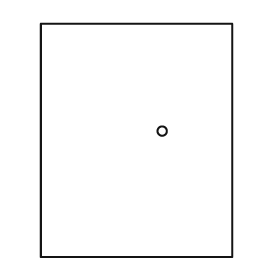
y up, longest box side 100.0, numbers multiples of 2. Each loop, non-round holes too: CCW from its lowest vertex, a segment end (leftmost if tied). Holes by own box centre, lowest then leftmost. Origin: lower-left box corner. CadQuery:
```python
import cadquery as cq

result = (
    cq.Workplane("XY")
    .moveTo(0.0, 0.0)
    .lineTo(82.0, 0.0)
    .lineTo(82.0, 100.0)
    .lineTo(0.0, 100.0)
    .close()
    .moveTo(52.0, 54.0)
    .circle(2.0)
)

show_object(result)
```